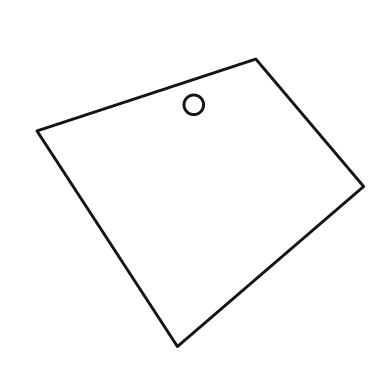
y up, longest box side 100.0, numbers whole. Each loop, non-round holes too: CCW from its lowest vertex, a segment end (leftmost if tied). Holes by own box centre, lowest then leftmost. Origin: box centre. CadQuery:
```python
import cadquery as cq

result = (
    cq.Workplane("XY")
    .moveTo(-7.0, -44.0)
    .lineTo(50.0, 5.0)
    .lineTo(17.0, 44.0)
    .lineTo(-50.0, 22.0)
    .close()
    .moveTo(-2.0, 30.0)
    .circle(3.0)
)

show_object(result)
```